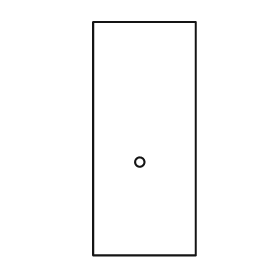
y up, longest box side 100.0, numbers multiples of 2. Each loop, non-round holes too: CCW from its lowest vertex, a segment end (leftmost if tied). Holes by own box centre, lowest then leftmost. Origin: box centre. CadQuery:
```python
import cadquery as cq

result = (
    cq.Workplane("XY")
    .moveTo(-22.0, -50.0)
    .lineTo(22.0, -50.0)
    .lineTo(22.0, 50.0)
    .lineTo(-22.0, 50.0)
    .close()
    .moveTo(-2.0, -10.0)
    .circle(2.0)
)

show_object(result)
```